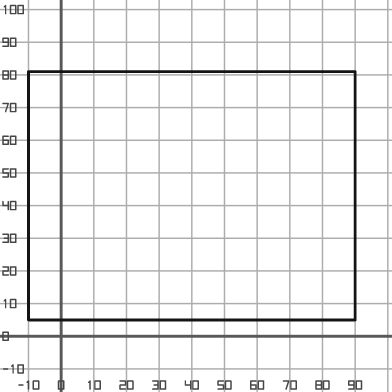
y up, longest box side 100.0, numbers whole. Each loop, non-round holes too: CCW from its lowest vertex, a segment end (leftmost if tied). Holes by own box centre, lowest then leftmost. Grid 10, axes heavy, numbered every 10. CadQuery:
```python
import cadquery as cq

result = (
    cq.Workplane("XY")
    .moveTo(-10.0, 5.0)
    .lineTo(90.0, 5.0)
    .lineTo(90.0, 81.0)
    .lineTo(-10.0, 81.0)
    .close()
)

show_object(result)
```